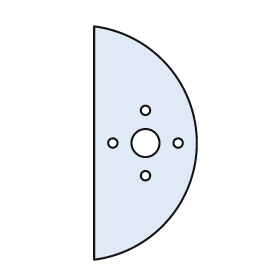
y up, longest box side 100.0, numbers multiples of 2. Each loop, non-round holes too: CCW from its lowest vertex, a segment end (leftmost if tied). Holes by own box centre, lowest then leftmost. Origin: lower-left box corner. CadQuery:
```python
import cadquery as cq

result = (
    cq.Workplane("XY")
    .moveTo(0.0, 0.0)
    .threePointArc((44.0, 50.0), (0.0, 100.0))
    .close()
    .moveTo(22.0, 36.0)
    .circle(2.0)
    .moveTo(8.0, 50.0)
    .circle(2.0)
    .moveTo(22.0, 50.0)
    .circle(6.0)
    .moveTo(36.0, 50.0)
    .circle(2.0)
    .moveTo(22.0, 64.0)
    .circle(2.0)
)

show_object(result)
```